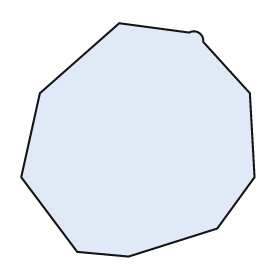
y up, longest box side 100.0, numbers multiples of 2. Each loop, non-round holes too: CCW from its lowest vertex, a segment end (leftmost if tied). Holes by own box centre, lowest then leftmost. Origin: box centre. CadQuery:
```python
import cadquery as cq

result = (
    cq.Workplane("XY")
    .moveTo(-4.0, -50.0)
    .lineTo(34.0, -38.0)
    .lineTo(50.0, -16.0)
    .lineTo(48.0, 20.0)
    .lineTo(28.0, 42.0)
    .threePointArc((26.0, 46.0), (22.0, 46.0))
    .lineTo(-8.0, 50.0)
    .lineTo(-42.0, 20.0)
    .lineTo(-50.0, -16.0)
    .lineTo(-26.0, -48.0)
    .close()
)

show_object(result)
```